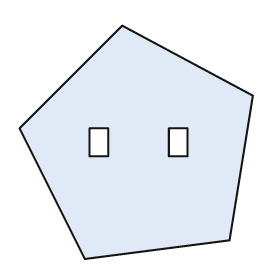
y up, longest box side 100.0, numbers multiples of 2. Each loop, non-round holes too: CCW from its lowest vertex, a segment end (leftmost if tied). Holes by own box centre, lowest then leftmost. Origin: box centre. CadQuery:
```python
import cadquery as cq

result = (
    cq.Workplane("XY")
    .moveTo(-22.0, -50.0)
    .lineTo(40.0, -42.0)
    .lineTo(50.0, 20.0)
    .lineTo(-6.0, 50.0)
    .lineTo(-50.0, 6.0)
    .close()
    .moveTo(-20.0, -6.0)
    .lineTo(-12.0, -6.0)
    .lineTo(-12.0, 6.0)
    .lineTo(-20.0, 6.0)
    .close()
    .moveTo(14.0, -6.0)
    .lineTo(22.0, -6.0)
    .lineTo(22.0, 6.0)
    .lineTo(14.0, 6.0)
    .close()
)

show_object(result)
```